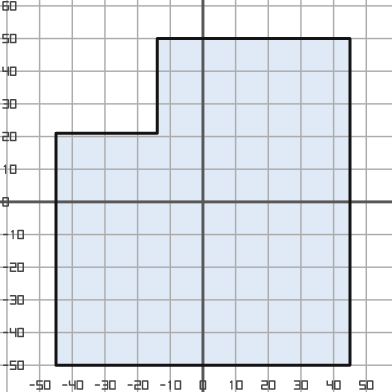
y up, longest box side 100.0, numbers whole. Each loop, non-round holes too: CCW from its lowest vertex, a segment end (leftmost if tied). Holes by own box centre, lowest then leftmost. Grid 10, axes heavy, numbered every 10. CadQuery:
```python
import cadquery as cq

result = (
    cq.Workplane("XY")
    .moveTo(-45.0, -50.0)
    .lineTo(45.0, -50.0)
    .lineTo(45.0, 50.0)
    .lineTo(-14.0, 50.0)
    .lineTo(-14.0, 21.0)
    .lineTo(-45.0, 21.0)
    .close()
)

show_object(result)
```